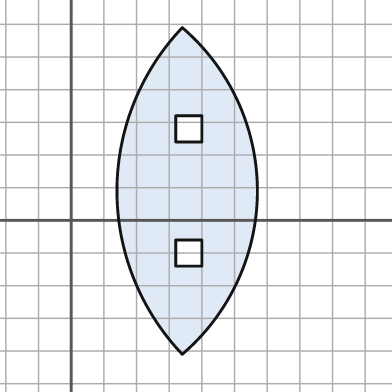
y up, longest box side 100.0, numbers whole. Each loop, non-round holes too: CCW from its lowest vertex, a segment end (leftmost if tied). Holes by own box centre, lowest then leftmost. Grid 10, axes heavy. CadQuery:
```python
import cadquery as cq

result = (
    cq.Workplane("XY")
    .moveTo(34.0, -41.0)
    .threePointArc((57.0, 9.0), (34.0, 59.0))
    .threePointArc((14.0, 9.0), (34.0, -41.0))
    .close()
    .moveTo(32.0, -14.0)
    .lineTo(40.0, -14.0)
    .lineTo(40.0, -6.0)
    .lineTo(32.0, -6.0)
    .close()
    .moveTo(32.0, 24.0)
    .lineTo(40.0, 24.0)
    .lineTo(40.0, 32.0)
    .lineTo(32.0, 32.0)
    .close()
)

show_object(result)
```